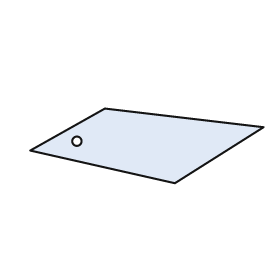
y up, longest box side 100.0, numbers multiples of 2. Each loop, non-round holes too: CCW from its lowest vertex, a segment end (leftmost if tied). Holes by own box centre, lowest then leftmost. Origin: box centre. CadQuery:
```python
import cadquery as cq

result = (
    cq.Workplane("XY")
    .moveTo(12.0, -16.0)
    .lineTo(50.0, 8.0)
    .lineTo(-18.0, 16.0)
    .lineTo(-50.0, -2.0)
    .close()
    .moveTo(-30.0, 2.0)
    .circle(2.0)
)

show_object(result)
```